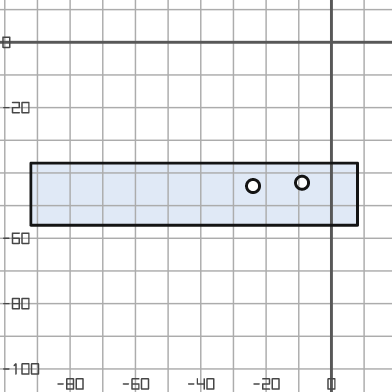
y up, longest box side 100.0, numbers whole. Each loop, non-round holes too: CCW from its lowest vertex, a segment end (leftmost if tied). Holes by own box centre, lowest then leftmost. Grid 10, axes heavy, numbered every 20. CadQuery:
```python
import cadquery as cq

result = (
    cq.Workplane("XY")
    .moveTo(-92.0, -56.0)
    .lineTo(8.0, -56.0)
    .lineTo(8.0, -37.0)
    .lineTo(-92.0, -37.0)
    .close()
    .moveTo(-24.0, -44.0)
    .circle(2.0)
    .moveTo(-9.0, -43.0)
    .circle(2.0)
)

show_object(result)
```